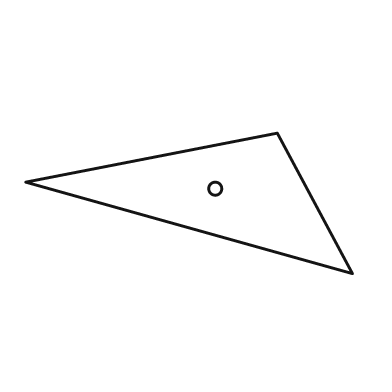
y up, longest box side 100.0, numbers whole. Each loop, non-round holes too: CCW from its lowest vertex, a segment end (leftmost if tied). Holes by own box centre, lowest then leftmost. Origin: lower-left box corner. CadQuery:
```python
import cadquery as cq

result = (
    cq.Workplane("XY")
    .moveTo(100.0, 0.0)
    .lineTo(77.0, 43.0)
    .lineTo(0.0, 28.0)
    .close()
    .moveTo(58.0, 26.0)
    .circle(2.0)
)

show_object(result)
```